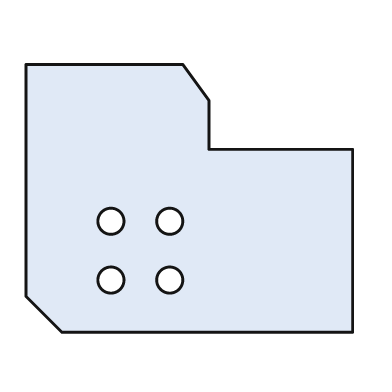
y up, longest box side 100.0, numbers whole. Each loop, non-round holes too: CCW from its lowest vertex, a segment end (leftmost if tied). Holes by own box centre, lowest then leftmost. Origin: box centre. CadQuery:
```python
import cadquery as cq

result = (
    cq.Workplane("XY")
    .moveTo(-39.0, -41.0)
    .lineTo(50.0, -41.0)
    .lineTo(50.0, 15.0)
    .lineTo(6.0, 15.0)
    .lineTo(6.0, 30.0)
    .lineTo(-2.0, 41.0)
    .lineTo(-50.0, 41.0)
    .lineTo(-50.0, -30.0)
    .close()
    .moveTo(-24.0, -25.0)
    .circle(4.0)
    .moveTo(-6.0, -25.0)
    .circle(4.0)
    .moveTo(-24.0, -7.0)
    .circle(4.0)
    .moveTo(-6.0, -7.0)
    .circle(4.0)
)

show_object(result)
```